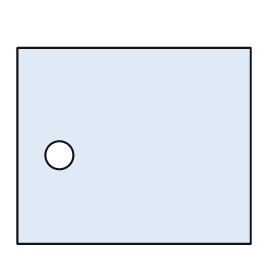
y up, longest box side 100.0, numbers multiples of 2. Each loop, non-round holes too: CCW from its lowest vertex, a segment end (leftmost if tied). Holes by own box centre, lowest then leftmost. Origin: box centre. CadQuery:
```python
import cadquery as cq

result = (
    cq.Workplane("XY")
    .moveTo(-50.0, -42.0)
    .lineTo(50.0, -42.0)
    .lineTo(50.0, 42.0)
    .lineTo(-50.0, 42.0)
    .close()
    .moveTo(-32.0, -4.0)
    .circle(6.0)
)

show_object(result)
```